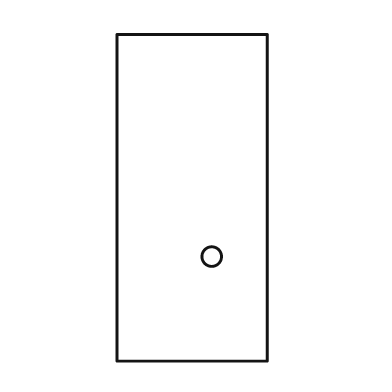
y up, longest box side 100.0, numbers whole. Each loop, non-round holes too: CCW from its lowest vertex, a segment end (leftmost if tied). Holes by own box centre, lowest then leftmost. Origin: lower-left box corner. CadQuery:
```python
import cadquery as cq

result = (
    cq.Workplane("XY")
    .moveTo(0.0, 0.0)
    .lineTo(46.0, 0.0)
    .lineTo(46.0, 100.0)
    .lineTo(0.0, 100.0)
    .close()
    .moveTo(29.0, 32.0)
    .circle(3.0)
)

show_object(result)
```